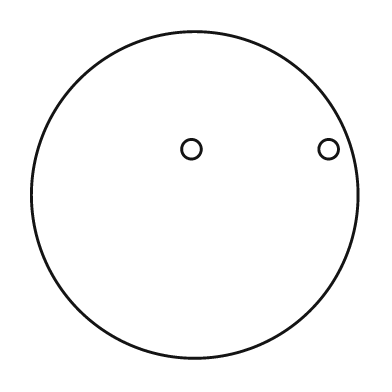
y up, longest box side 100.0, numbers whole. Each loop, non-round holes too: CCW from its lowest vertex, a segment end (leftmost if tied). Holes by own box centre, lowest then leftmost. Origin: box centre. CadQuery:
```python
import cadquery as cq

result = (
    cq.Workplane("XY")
    .moveTo(0.0, 0.0)
    .circle(50.0)
    .moveTo(-1.0, 14.0)
    .circle(3.0)
    .moveTo(41.0, 14.0)
    .circle(3.0)
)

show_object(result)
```